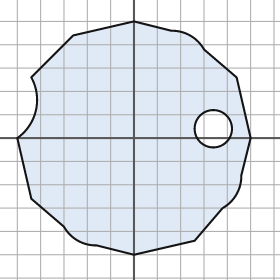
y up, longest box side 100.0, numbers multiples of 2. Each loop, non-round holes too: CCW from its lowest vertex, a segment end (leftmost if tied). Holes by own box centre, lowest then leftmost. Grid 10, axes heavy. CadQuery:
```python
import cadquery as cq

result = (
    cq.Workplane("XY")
    .moveTo(0.0, -50.0)
    .lineTo(26.0, -44.0)
    .lineTo(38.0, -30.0)
    .threePointArc((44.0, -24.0), (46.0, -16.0))
    .lineTo(50.0, 0.0)
    .lineTo(44.0, 26.0)
    .lineTo(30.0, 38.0)
    .threePointArc((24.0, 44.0), (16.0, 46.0))
    .lineTo(0.0, 50.0)
    .lineTo(-26.0, 44.0)
    .lineTo(-44.0, 26.0)
    .threePointArc((-42.0, 12.0), (-50.0, 0.0))
    .lineTo(-44.0, -26.0)
    .lineTo(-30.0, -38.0)
    .threePointArc((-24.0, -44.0), (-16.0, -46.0))
    .close()
    .moveTo(34.0, 4.0)
    .circle(8.0)
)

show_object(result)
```